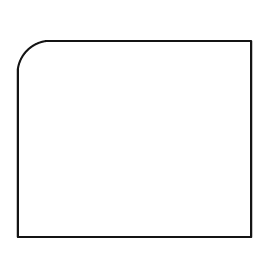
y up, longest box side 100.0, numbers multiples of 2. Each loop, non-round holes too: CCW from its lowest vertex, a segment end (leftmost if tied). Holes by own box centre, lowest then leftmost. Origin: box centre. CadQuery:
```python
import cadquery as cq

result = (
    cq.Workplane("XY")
    .moveTo(-50.0, -42.0)
    .lineTo(50.0, -42.0)
    .lineTo(50.0, 42.0)
    .lineTo(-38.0, 42.0)
    .threePointArc((-46.0, 38.0), (-50.0, 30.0))
    .close()
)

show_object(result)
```